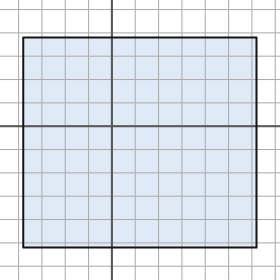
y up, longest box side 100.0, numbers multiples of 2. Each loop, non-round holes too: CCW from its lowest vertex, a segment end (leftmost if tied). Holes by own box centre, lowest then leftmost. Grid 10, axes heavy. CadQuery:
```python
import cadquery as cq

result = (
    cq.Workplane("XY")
    .moveTo(-38.0, -52.0)
    .lineTo(62.0, -52.0)
    .lineTo(62.0, 38.0)
    .lineTo(-38.0, 38.0)
    .close()
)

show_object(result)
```